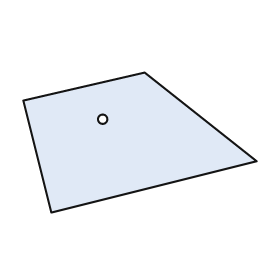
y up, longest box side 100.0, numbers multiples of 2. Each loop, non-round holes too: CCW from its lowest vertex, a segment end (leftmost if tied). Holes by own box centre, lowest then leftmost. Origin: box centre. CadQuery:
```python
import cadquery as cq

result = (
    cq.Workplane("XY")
    .moveTo(-38.0, -30.0)
    .lineTo(50.0, -8.0)
    .lineTo(2.0, 30.0)
    .lineTo(-50.0, 18.0)
    .close()
    .moveTo(-16.0, 10.0)
    .circle(2.0)
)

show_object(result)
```